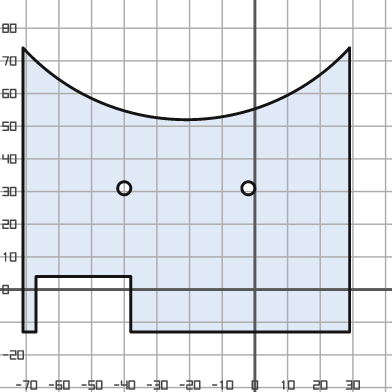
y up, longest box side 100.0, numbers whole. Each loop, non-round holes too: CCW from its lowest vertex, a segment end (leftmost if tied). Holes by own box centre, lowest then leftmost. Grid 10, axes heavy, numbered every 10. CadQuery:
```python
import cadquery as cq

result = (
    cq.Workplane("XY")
    .moveTo(-71.0, -13.0)
    .lineTo(-67.0, -13.0)
    .lineTo(-67.0, 4.0)
    .lineTo(-38.0, 4.0)
    .lineTo(-38.0, -13.0)
    .lineTo(29.0, -13.0)
    .lineTo(29.0, 74.0)
    .threePointArc((-21.0, 52.0), (-71.0, 74.0))
    .close()
    .moveTo(-40.0, 31.0)
    .circle(2.0)
    .moveTo(-2.0, 31.0)
    .circle(2.0)
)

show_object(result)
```